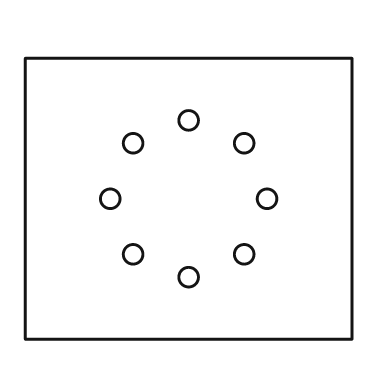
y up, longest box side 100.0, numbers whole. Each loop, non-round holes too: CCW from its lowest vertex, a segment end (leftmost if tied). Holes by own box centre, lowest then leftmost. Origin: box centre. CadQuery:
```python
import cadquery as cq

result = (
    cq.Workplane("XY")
    .moveTo(-50.0, -43.0)
    .lineTo(50.0, -43.0)
    .lineTo(50.0, 43.0)
    .lineTo(-50.0, 43.0)
    .close()
    .moveTo(0.0, -24.0)
    .circle(3.0)
    .moveTo(-17.0, -17.0)
    .circle(3.0)
    .moveTo(17.0, -17.0)
    .circle(3.0)
    .moveTo(-24.0, 0.0)
    .circle(3.0)
    .moveTo(24.0, 0.0)
    .circle(3.0)
    .moveTo(-17.0, 17.0)
    .circle(3.0)
    .moveTo(17.0, 17.0)
    .circle(3.0)
    .moveTo(0.0, 24.0)
    .circle(3.0)
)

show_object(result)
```